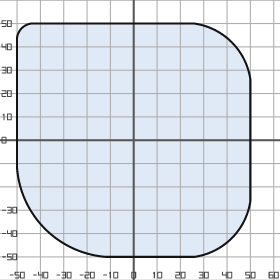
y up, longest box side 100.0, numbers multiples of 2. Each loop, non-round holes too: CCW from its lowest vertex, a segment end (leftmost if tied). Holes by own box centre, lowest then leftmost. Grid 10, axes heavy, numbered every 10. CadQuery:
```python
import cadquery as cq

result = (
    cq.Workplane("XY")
    .moveTo(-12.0, -50.0)
    .lineTo(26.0, -50.0)
    .threePointArc((42.0, -42.0), (50.0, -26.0))
    .lineTo(50.0, 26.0)
    .threePointArc((42.0, 42.0), (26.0, 50.0))
    .lineTo(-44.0, 50.0)
    .threePointArc((-48.0, 48.0), (-50.0, 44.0))
    .lineTo(-50.0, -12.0)
    .threePointArc((-38.0, -38.0), (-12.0, -50.0))
    .close()
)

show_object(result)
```